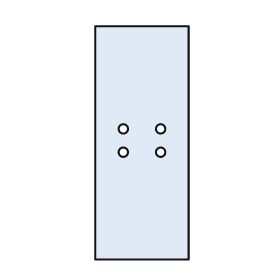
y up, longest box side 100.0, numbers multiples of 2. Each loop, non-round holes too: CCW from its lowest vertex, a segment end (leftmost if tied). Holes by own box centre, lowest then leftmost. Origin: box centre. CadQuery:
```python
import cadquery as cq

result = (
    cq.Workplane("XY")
    .moveTo(-20.0, -50.0)
    .lineTo(20.0, -50.0)
    .lineTo(20.0, 50.0)
    .lineTo(-20.0, 50.0)
    .close()
    .moveTo(-8.0, -4.0)
    .circle(2.0)
    .moveTo(8.0, -4.0)
    .circle(2.0)
    .moveTo(-8.0, 6.0)
    .circle(2.0)
    .moveTo(8.0, 6.0)
    .circle(2.0)
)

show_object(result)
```